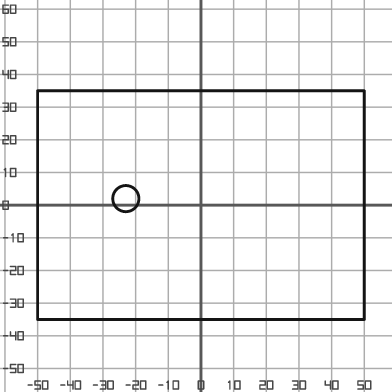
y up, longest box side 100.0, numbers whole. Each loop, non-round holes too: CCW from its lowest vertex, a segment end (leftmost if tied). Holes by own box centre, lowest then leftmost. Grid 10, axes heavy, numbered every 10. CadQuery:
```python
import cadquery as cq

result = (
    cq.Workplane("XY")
    .moveTo(-50.0, -35.0)
    .lineTo(50.0, -35.0)
    .lineTo(50.0, 35.0)
    .lineTo(-50.0, 35.0)
    .close()
    .moveTo(-23.0, 2.0)
    .circle(4.0)
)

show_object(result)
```